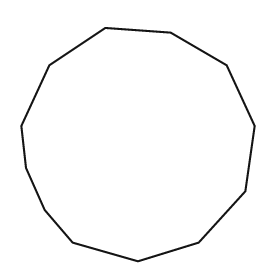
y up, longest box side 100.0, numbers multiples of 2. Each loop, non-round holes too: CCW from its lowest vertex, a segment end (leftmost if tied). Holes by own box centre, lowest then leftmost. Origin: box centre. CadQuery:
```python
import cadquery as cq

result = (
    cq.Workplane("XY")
    .moveTo(0.0, -50.0)
    .lineTo(26.0, -42.0)
    .lineTo(46.0, -20.0)
    .lineTo(50.0, 8.0)
    .lineTo(38.0, 34.0)
    .lineTo(14.0, 48.0)
    .lineTo(-14.0, 50.0)
    .lineTo(-38.0, 34.0)
    .lineTo(-50.0, 8.0)
    .lineTo(-48.0, -10.0)
    .lineTo(-40.0, -28.0)
    .lineTo(-28.0, -42.0)
    .close()
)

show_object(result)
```